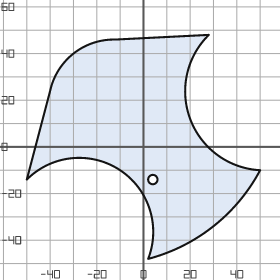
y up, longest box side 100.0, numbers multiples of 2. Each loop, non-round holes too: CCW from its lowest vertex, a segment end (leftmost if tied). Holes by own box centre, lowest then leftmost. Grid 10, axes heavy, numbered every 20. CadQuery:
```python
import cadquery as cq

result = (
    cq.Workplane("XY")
    .moveTo(2.0, -48.0)
    .threePointArc((30.0, -34.0), (50.0, -10.0))
    .threePointArc((20.0, 12.0), (28.0, 48.0))
    .lineTo(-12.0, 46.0)
    .threePointArc((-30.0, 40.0), (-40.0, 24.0))
    .lineTo(-50.0, -14.0)
    .threePointArc((-10.0, -10.0), (2.0, -48.0))
    .close()
    .moveTo(4.0, -14.0)
    .circle(2.0)
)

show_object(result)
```